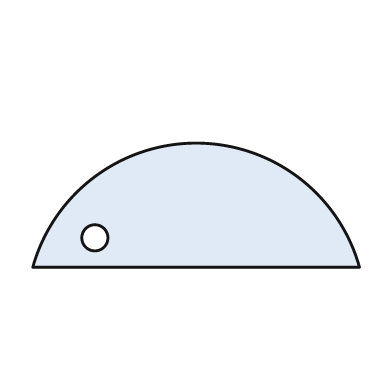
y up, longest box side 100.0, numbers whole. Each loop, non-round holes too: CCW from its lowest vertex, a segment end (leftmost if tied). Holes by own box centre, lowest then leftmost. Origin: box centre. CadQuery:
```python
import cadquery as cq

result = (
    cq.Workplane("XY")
    .moveTo(-50.0, -19.0)
    .lineTo(50.0, -19.0)
    .threePointArc((0.0, 19.0), (-50.0, -19.0))
    .close()
    .moveTo(-31.0, -10.0)
    .circle(4.0)
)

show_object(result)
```